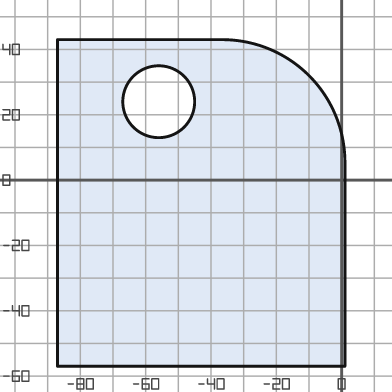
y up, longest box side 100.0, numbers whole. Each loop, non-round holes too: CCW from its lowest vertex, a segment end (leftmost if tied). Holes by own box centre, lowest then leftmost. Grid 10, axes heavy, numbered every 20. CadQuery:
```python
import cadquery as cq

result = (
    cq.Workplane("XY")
    .moveTo(-87.0, -57.0)
    .lineTo(1.0, -57.0)
    .lineTo(1.0, 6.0)
    .threePointArc((-10.0, 32.0), (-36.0, 43.0))
    .lineTo(-87.0, 43.0)
    .close()
    .moveTo(-56.0, 24.0)
    .circle(11.0)
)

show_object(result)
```